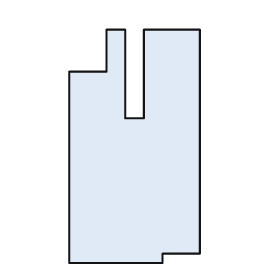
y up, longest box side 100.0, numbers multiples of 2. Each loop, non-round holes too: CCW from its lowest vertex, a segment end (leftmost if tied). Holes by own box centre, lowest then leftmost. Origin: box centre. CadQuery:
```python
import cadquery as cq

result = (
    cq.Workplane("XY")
    .moveTo(-28.0, -50.0)
    .lineTo(12.0, -50.0)
    .lineTo(12.0, -46.0)
    .lineTo(28.0, -46.0)
    .lineTo(28.0, 50.0)
    .lineTo(4.0, 50.0)
    .lineTo(4.0, 12.0)
    .lineTo(-4.0, 12.0)
    .lineTo(-4.0, 50.0)
    .lineTo(-12.0, 50.0)
    .lineTo(-12.0, 32.0)
    .lineTo(-28.0, 32.0)
    .close()
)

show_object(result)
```